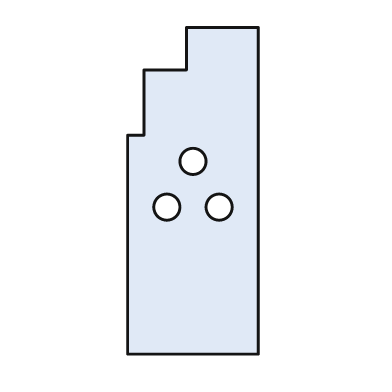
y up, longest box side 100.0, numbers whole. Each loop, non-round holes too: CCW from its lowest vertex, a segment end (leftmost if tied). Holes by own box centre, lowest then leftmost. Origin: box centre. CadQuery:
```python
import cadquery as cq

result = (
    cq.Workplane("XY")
    .moveTo(-20.0, -50.0)
    .lineTo(20.0, -50.0)
    .lineTo(20.0, 50.0)
    .lineTo(-2.0, 50.0)
    .lineTo(-2.0, 37.0)
    .lineTo(-15.0, 37.0)
    .lineTo(-15.0, 17.0)
    .lineTo(-20.0, 17.0)
    .close()
    .moveTo(-8.0, -5.0)
    .circle(4.0)
    .moveTo(8.0, -5.0)
    .circle(4.0)
    .moveTo(0.0, 9.0)
    .circle(4.0)
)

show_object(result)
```